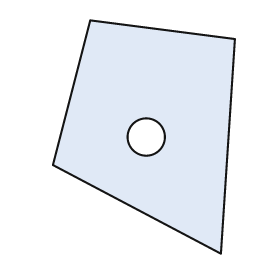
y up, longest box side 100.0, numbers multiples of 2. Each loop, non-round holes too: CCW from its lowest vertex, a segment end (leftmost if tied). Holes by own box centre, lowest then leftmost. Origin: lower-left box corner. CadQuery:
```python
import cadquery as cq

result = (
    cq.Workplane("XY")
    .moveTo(72.0, 0.0)
    .lineTo(78.0, 92.0)
    .lineTo(16.0, 100.0)
    .lineTo(0.0, 38.0)
    .close()
    .moveTo(40.0, 50.0)
    .circle(8.0)
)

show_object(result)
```